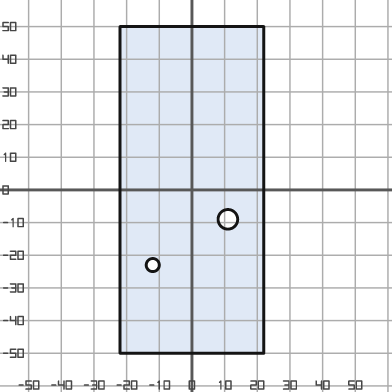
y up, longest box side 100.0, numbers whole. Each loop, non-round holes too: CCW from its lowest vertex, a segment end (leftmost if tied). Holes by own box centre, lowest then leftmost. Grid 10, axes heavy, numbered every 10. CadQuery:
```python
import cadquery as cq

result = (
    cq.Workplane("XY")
    .moveTo(-22.0, -50.0)
    .lineTo(22.0, -50.0)
    .lineTo(22.0, 50.0)
    .lineTo(-22.0, 50.0)
    .close()
    .moveTo(-12.0, -23.0)
    .circle(2.0)
    .moveTo(11.0, -9.0)
    .circle(3.0)
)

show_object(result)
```